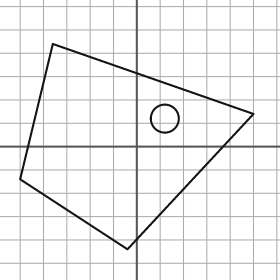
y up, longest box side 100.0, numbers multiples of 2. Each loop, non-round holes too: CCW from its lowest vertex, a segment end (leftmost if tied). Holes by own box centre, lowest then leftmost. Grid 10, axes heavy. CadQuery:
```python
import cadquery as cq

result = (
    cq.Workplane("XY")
    .moveTo(-4.0, -44.0)
    .lineTo(50.0, 14.0)
    .lineTo(-36.0, 44.0)
    .lineTo(-50.0, -14.0)
    .close()
    .moveTo(12.0, 12.0)
    .circle(6.0)
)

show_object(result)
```